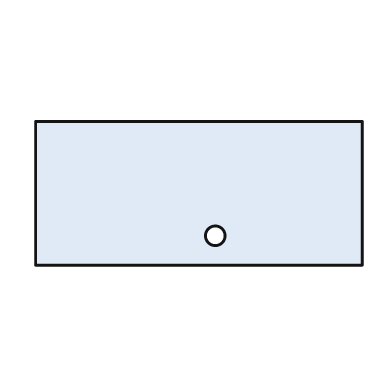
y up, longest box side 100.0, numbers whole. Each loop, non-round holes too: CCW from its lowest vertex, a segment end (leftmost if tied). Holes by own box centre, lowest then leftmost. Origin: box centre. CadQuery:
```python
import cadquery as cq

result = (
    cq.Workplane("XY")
    .moveTo(-50.0, -22.0)
    .lineTo(50.0, -22.0)
    .lineTo(50.0, 22.0)
    .lineTo(-50.0, 22.0)
    .close()
    .moveTo(5.0, -13.0)
    .circle(3.0)
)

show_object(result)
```